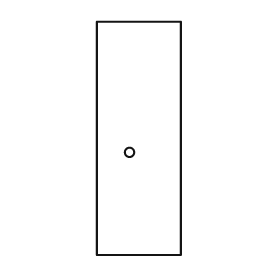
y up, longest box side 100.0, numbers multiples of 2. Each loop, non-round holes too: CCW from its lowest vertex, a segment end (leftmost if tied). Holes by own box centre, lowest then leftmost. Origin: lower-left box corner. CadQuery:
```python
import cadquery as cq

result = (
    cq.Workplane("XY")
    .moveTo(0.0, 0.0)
    .lineTo(36.0, 0.0)
    .lineTo(36.0, 100.0)
    .lineTo(0.0, 100.0)
    .close()
    .moveTo(14.0, 44.0)
    .circle(2.0)
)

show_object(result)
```